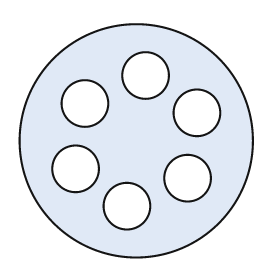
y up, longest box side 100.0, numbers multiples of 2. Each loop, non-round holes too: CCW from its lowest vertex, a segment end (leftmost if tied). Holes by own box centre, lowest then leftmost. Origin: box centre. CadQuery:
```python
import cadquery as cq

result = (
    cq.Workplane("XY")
    .moveTo(0.0, 0.0)
    .circle(50.0)
    .moveTo(-4.0, -28.0)
    .circle(10.0)
    .moveTo(22.0, -16.0)
    .circle(10.0)
    .moveTo(-26.0, -12.0)
    .circle(10.0)
    .moveTo(26.0, 12.0)
    .circle(10.0)
    .moveTo(-22.0, 16.0)
    .circle(10.0)
    .moveTo(4.0, 28.0)
    .circle(10.0)
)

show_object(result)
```